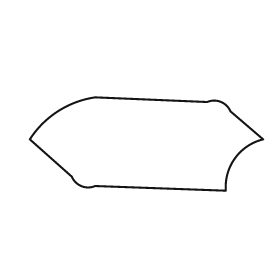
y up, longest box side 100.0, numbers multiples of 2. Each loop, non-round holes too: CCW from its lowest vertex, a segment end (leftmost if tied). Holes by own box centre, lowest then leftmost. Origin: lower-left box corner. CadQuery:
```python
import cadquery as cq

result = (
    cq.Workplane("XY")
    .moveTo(84.0, 0.0)
    .threePointArc((88.0, 14.0), (100.0, 22.0))
    .lineTo(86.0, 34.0)
    .threePointArc((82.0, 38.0), (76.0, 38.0))
    .lineTo(28.0, 40.0)
    .threePointArc((12.0, 34.0), (0.0, 22.0))
    .lineTo(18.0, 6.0)
    .threePointArc((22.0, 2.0), (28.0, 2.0))
    .close()
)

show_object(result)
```